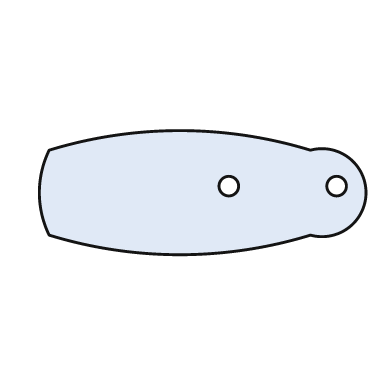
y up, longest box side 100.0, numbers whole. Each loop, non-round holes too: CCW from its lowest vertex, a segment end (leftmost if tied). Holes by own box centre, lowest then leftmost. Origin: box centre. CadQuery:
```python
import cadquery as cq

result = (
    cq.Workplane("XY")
    .moveTo(-47.0, -13.0)
    .threePointArc((-7.0, -19.0), (33.0, -13.0))
    .threePointArc((50.0, 0.0), (33.0, 13.0))
    .threePointArc((-7.0, 19.0), (-47.0, 13.0))
    .threePointArc((-50.0, 0.0), (-47.0, -13.0))
    .close()
    .moveTo(8.0, 2.0)
    .circle(3.0)
    .moveTo(41.0, 2.0)
    .circle(3.0)
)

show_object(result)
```